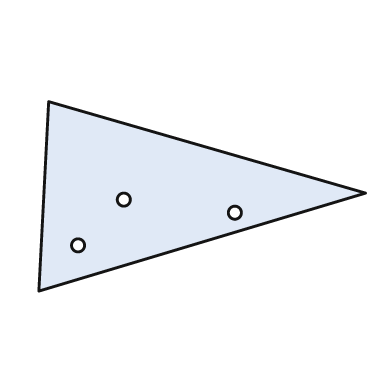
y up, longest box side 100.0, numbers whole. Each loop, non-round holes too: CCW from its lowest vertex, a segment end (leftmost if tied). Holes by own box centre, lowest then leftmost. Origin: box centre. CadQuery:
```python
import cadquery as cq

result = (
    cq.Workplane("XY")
    .moveTo(-50.0, -29.0)
    .lineTo(50.0, 1.0)
    .lineTo(-47.0, 29.0)
    .close()
    .moveTo(-38.0, -15.0)
    .circle(2.0)
    .moveTo(10.0, -5.0)
    .circle(2.0)
    .moveTo(-24.0, -1.0)
    .circle(2.0)
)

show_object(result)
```